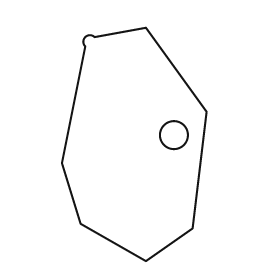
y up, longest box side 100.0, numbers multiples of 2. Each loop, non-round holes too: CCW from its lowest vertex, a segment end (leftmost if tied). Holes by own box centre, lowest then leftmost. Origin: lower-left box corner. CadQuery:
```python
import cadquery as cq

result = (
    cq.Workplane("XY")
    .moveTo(36.0, 0.0)
    .lineTo(56.0, 14.0)
    .lineTo(62.0, 64.0)
    .lineTo(36.0, 100.0)
    .lineTo(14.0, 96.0)
    .threePointArc((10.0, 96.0), (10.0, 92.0))
    .lineTo(0.0, 42.0)
    .lineTo(8.0, 16.0)
    .close()
    .moveTo(48.0, 54.0)
    .circle(6.0)
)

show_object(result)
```